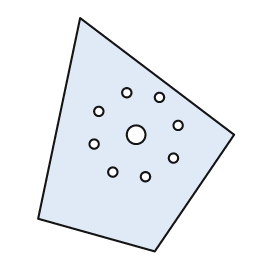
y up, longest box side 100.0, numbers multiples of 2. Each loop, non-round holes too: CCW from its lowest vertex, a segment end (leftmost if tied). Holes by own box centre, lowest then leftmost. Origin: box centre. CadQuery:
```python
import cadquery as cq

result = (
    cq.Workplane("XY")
    .moveTo(8.0, -50.0)
    .lineTo(42.0, 0.0)
    .lineTo(-24.0, 50.0)
    .lineTo(-42.0, -36.0)
    .close()
    .moveTo(4.0, -18.0)
    .circle(2.0)
    .moveTo(-10.0, -16.0)
    .circle(2.0)
    .moveTo(16.0, -10.0)
    .circle(2.0)
    .moveTo(-18.0, -4.0)
    .circle(2.0)
    .moveTo(0.0, 0.0)
    .circle(4.0)
    .moveTo(18.0, 4.0)
    .circle(2.0)
    .moveTo(-16.0, 10.0)
    .circle(2.0)
    .moveTo(10.0, 16.0)
    .circle(2.0)
    .moveTo(-4.0, 18.0)
    .circle(2.0)
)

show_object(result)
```